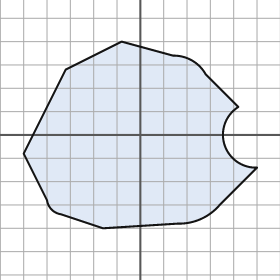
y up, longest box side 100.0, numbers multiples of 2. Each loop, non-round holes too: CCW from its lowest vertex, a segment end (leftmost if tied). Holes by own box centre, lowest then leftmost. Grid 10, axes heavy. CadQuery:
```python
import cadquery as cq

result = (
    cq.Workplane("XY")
    .moveTo(-16.0, -40.0)
    .lineTo(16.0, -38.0)
    .threePointArc((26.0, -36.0), (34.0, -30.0))
    .lineTo(50.0, -14.0)
    .threePointArc((36.0, -4.0), (42.0, 12.0))
    .lineTo(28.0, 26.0)
    .threePointArc((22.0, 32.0), (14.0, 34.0))
    .lineTo(-8.0, 40.0)
    .lineTo(-32.0, 28.0)
    .lineTo(-50.0, -8.0)
    .lineTo(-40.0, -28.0)
    .threePointArc((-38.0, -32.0), (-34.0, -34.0))
    .close()
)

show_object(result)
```